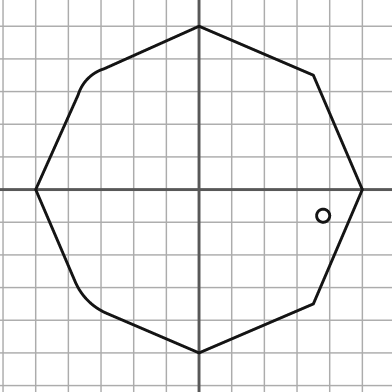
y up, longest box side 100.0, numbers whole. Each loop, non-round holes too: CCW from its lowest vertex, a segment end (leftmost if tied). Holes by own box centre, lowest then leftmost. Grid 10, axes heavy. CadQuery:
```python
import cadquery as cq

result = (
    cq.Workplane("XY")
    .moveTo(0.0, -50.0)
    .lineTo(35.0, -35.0)
    .lineTo(50.0, 0.0)
    .lineTo(35.0, 35.0)
    .lineTo(0.0, 50.0)
    .lineTo(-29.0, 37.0)
    .threePointArc((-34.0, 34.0), (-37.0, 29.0))
    .lineTo(-50.0, 0.0)
    .lineTo(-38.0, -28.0)
    .threePointArc((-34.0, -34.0), (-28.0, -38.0))
    .close()
    .moveTo(38.0, -8.0)
    .circle(2.0)
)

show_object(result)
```